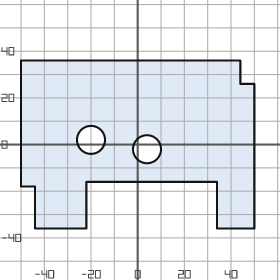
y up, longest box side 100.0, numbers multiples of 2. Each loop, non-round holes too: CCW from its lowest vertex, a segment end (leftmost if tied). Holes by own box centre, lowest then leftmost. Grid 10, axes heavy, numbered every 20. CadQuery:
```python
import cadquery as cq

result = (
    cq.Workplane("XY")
    .moveTo(-44.0, -36.0)
    .lineTo(-22.0, -36.0)
    .lineTo(-22.0, -16.0)
    .lineTo(34.0, -16.0)
    .lineTo(34.0, -36.0)
    .lineTo(50.0, -36.0)
    .lineTo(50.0, 26.0)
    .lineTo(44.0, 26.0)
    .lineTo(44.0, 36.0)
    .lineTo(-50.0, 36.0)
    .lineTo(-50.0, -18.0)
    .lineTo(-44.0, -18.0)
    .close()
    .moveTo(4.0, -2.0)
    .circle(6.0)
    .moveTo(-20.0, 2.0)
    .circle(6.0)
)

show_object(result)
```